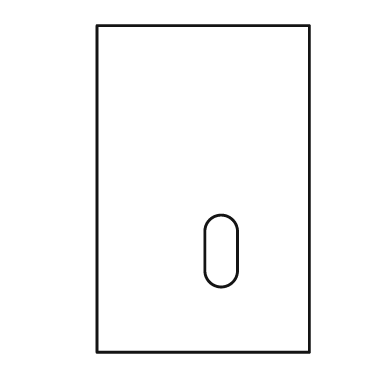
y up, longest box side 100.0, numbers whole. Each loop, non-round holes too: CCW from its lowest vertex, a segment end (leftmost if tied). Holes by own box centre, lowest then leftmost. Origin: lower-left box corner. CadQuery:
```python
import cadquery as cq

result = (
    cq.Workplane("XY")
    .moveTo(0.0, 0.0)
    .lineTo(65.0, 0.0)
    .lineTo(65.0, 100.0)
    .lineTo(0.0, 100.0)
    .close()
    .moveTo(33.0, 25.0)
    .threePointArc((38.0, 20.0), (43.0, 25.0))
    .lineTo(43.0, 37.0)
    .threePointArc((38.0, 42.0), (33.0, 37.0))
    .close()
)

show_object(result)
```